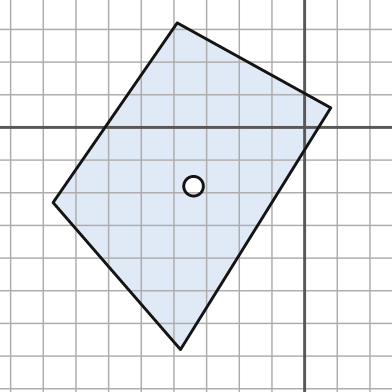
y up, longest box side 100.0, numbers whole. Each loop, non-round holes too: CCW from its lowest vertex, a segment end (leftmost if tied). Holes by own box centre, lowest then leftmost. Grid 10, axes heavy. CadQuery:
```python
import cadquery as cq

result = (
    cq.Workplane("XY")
    .moveTo(-38.0, -68.0)
    .lineTo(8.0, 6.0)
    .lineTo(-39.0, 32.0)
    .lineTo(-77.0, -23.0)
    .close()
    .moveTo(-34.0, -18.0)
    .circle(3.0)
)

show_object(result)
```